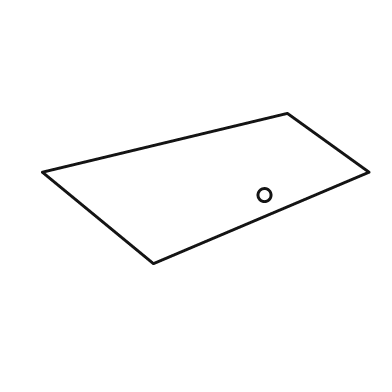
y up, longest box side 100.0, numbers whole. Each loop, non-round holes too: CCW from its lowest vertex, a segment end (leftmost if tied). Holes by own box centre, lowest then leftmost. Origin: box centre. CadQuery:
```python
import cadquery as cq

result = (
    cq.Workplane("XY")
    .moveTo(-16.0, -23.0)
    .lineTo(50.0, 5.0)
    .lineTo(25.0, 23.0)
    .lineTo(-50.0, 5.0)
    .close()
    .moveTo(18.0, -2.0)
    .circle(2.0)
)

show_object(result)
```